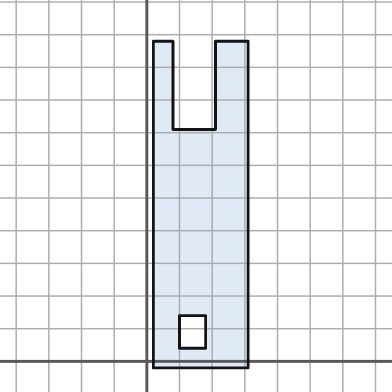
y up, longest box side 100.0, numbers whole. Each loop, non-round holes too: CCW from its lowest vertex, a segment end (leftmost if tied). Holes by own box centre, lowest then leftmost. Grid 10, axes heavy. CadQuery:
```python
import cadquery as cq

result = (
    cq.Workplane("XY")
    .moveTo(2.0, -2.0)
    .lineTo(31.0, -2.0)
    .lineTo(31.0, 98.0)
    .lineTo(21.0, 98.0)
    .lineTo(21.0, 71.0)
    .lineTo(8.0, 71.0)
    .lineTo(8.0, 98.0)
    .lineTo(2.0, 98.0)
    .close()
    .moveTo(10.0, 4.0)
    .lineTo(18.0, 4.0)
    .lineTo(18.0, 14.0)
    .lineTo(10.0, 14.0)
    .close()
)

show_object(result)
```